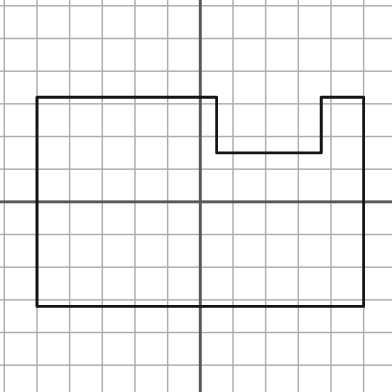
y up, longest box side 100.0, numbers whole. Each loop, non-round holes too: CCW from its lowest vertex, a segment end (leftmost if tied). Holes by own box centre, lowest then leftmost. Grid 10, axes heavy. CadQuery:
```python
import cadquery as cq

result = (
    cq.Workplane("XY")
    .moveTo(-50.0, -32.0)
    .lineTo(50.0, -32.0)
    .lineTo(50.0, 32.0)
    .lineTo(37.0, 32.0)
    .lineTo(37.0, 15.0)
    .lineTo(5.0, 15.0)
    .lineTo(5.0, 32.0)
    .lineTo(-50.0, 32.0)
    .close()
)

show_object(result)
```